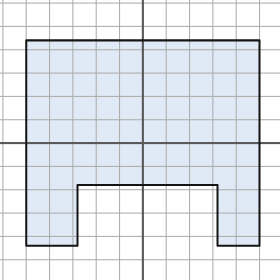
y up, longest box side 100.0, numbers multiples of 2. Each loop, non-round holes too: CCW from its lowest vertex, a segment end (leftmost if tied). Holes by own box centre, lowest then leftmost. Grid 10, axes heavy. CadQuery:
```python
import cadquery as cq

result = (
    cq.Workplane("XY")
    .moveTo(-50.0, -44.0)
    .lineTo(-28.0, -44.0)
    .lineTo(-28.0, -18.0)
    .lineTo(32.0, -18.0)
    .lineTo(32.0, -44.0)
    .lineTo(50.0, -44.0)
    .lineTo(50.0, 44.0)
    .lineTo(-50.0, 44.0)
    .close()
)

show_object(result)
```